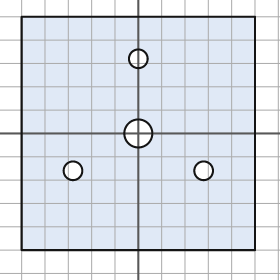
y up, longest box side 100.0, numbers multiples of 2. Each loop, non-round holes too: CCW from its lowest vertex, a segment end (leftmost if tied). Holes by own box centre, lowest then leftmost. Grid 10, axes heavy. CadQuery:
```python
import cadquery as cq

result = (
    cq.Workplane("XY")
    .moveTo(-50.0, -50.0)
    .lineTo(50.0, -50.0)
    .lineTo(50.0, 50.0)
    .lineTo(-50.0, 50.0)
    .close()
    .moveTo(-28.0, -16.0)
    .circle(4.0)
    .moveTo(28.0, -16.0)
    .circle(4.0)
    .moveTo(0.0, 0.0)
    .circle(6.0)
    .moveTo(0.0, 32.0)
    .circle(4.0)
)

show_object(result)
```